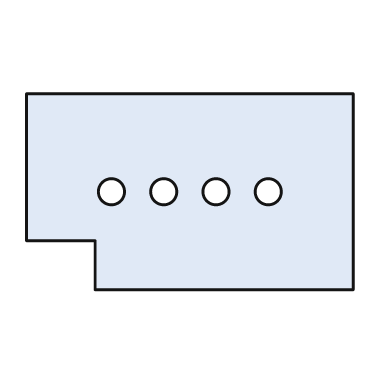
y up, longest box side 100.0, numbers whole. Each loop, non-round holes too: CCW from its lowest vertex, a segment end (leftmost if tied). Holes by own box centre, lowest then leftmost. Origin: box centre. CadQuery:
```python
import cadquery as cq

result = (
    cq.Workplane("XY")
    .moveTo(-29.0, -30.0)
    .lineTo(50.0, -30.0)
    .lineTo(50.0, 30.0)
    .lineTo(-50.0, 30.0)
    .lineTo(-50.0, -15.0)
    .lineTo(-29.0, -15.0)
    .close()
    .moveTo(-24.0, 0.0)
    .circle(4.0)
    .moveTo(-8.0, 0.0)
    .circle(4.0)
    .moveTo(8.0, 0.0)
    .circle(4.0)
    .moveTo(24.0, 0.0)
    .circle(4.0)
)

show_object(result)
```